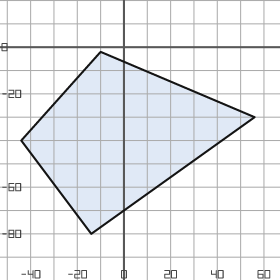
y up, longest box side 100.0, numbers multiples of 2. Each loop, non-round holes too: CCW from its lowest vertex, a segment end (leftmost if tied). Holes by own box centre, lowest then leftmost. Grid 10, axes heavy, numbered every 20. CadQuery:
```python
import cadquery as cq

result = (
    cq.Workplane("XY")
    .moveTo(-14.0, -80.0)
    .lineTo(56.0, -30.0)
    .lineTo(-10.0, -2.0)
    .lineTo(-44.0, -40.0)
    .close()
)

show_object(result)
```